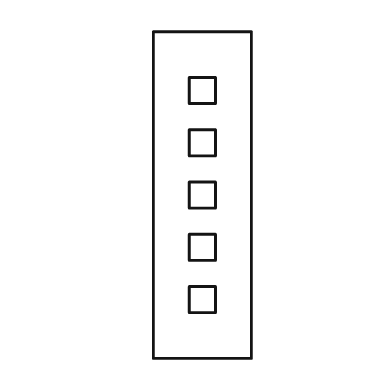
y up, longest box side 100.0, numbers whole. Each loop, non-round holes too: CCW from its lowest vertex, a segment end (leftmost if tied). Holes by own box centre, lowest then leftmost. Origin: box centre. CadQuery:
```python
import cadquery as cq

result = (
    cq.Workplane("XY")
    .moveTo(-15.0, -50.0)
    .lineTo(15.0, -50.0)
    .lineTo(15.0, 50.0)
    .lineTo(-15.0, 50.0)
    .close()
    .moveTo(-4.0, -36.0)
    .lineTo(4.0, -36.0)
    .lineTo(4.0, -28.0)
    .lineTo(-4.0, -28.0)
    .close()
    .moveTo(-4.0, -20.0)
    .lineTo(4.0, -20.0)
    .lineTo(4.0, -12.0)
    .lineTo(-4.0, -12.0)
    .close()
    .moveTo(-4.0, -4.0)
    .lineTo(4.0, -4.0)
    .lineTo(4.0, 4.0)
    .lineTo(-4.0, 4.0)
    .close()
    .moveTo(-4.0, 12.0)
    .lineTo(4.0, 12.0)
    .lineTo(4.0, 20.0)
    .lineTo(-4.0, 20.0)
    .close()
    .moveTo(-4.0, 28.0)
    .lineTo(4.0, 28.0)
    .lineTo(4.0, 36.0)
    .lineTo(-4.0, 36.0)
    .close()
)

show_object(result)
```